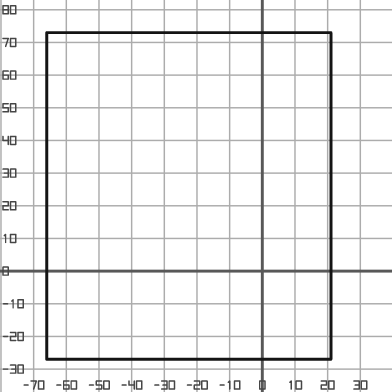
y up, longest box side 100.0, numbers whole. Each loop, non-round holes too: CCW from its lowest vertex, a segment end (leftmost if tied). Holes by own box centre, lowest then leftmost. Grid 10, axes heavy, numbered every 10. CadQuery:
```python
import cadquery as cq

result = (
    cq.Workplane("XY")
    .moveTo(-66.0, -27.0)
    .lineTo(21.0, -27.0)
    .lineTo(21.0, 73.0)
    .lineTo(-66.0, 73.0)
    .close()
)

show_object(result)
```